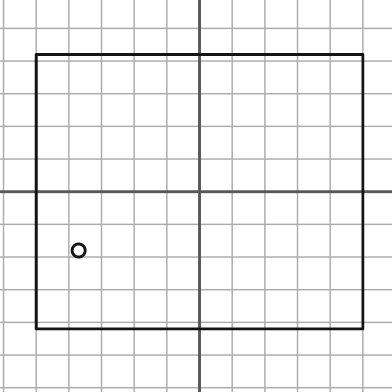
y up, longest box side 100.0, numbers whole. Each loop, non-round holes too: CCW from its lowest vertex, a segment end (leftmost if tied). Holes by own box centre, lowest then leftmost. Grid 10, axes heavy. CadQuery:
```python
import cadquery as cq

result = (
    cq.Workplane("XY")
    .moveTo(-50.0, -42.0)
    .lineTo(50.0, -42.0)
    .lineTo(50.0, 42.0)
    .lineTo(-50.0, 42.0)
    .close()
    .moveTo(-37.0, -18.0)
    .circle(2.0)
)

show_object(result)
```